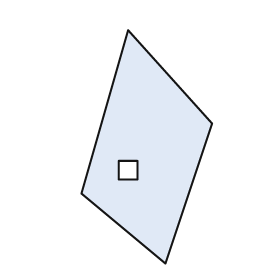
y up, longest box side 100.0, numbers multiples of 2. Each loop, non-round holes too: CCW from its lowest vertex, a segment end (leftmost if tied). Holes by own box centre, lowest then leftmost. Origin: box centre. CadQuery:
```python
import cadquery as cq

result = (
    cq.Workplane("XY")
    .moveTo(8.0, -50.0)
    .lineTo(28.0, 10.0)
    .lineTo(-8.0, 50.0)
    .lineTo(-28.0, -20.0)
    .close()
    .moveTo(-12.0, -14.0)
    .lineTo(-4.0, -14.0)
    .lineTo(-4.0, -6.0)
    .lineTo(-12.0, -6.0)
    .close()
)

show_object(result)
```